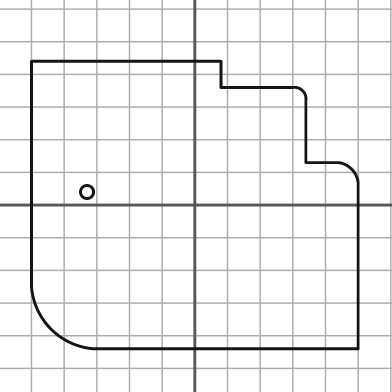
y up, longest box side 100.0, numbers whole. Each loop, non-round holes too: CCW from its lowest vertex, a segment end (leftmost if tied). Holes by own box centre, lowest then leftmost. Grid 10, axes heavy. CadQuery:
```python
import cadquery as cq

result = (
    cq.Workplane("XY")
    .moveTo(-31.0, -44.0)
    .lineTo(50.0, -44.0)
    .lineTo(50.0, 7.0)
    .threePointArc((48.0, 11.0), (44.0, 13.0))
    .lineTo(34.0, 13.0)
    .lineTo(34.0, 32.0)
    .threePointArc((33.0, 35.0), (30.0, 36.0))
    .lineTo(8.0, 36.0)
    .lineTo(8.0, 44.0)
    .lineTo(-50.0, 44.0)
    .lineTo(-50.0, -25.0)
    .threePointArc((-44.0, -38.0), (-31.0, -44.0))
    .close()
    .moveTo(-33.0, 4.0)
    .circle(2.0)
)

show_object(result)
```